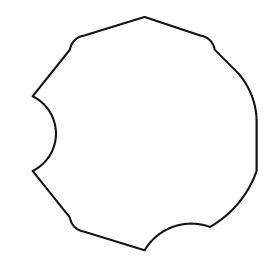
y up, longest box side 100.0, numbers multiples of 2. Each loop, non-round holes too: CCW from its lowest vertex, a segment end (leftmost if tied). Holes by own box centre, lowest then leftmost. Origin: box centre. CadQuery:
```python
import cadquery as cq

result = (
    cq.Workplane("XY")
    .moveTo(0.0, -50.0)
    .threePointArc((12.0, -40.0), (28.0, -40.0))
    .threePointArc((40.0, -30.0), (48.0, -16.0))
    .lineTo(48.0, 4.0)
    .threePointArc((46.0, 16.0), (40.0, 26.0))
    .lineTo(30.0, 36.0)
    .threePointArc((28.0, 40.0), (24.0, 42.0))
    .lineTo(0.0, 50.0)
    .lineTo(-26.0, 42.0)
    .threePointArc((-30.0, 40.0), (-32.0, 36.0))
    .lineTo(-48.0, 16.0)
    .threePointArc((-38.0, 0.0), (-48.0, -16.0))
    .lineTo(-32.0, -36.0)
    .threePointArc((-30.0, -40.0), (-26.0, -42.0))
    .close()
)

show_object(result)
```